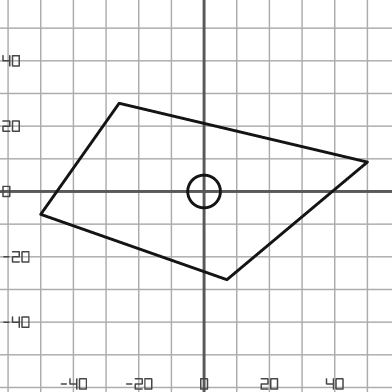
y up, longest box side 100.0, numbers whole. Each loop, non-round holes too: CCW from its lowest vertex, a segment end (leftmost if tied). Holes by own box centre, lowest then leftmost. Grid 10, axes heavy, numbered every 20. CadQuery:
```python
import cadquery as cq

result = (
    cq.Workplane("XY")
    .moveTo(7.0, -27.0)
    .lineTo(50.0, 9.0)
    .lineTo(-26.0, 27.0)
    .lineTo(-50.0, -7.0)
    .close()
    .moveTo(0.0, 0.0)
    .circle(5.0)
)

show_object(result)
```